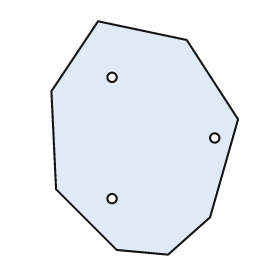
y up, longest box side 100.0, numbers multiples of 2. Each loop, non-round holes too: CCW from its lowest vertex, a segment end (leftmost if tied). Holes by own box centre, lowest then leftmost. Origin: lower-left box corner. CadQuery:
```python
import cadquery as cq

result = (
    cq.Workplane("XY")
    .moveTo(50.0, 0.0)
    .lineTo(68.0, 16.0)
    .lineTo(80.0, 58.0)
    .lineTo(58.0, 92.0)
    .lineTo(20.0, 100.0)
    .lineTo(0.0, 70.0)
    .lineTo(2.0, 28.0)
    .lineTo(28.0, 2.0)
    .close()
    .moveTo(26.0, 24.0)
    .circle(2.0)
    .moveTo(70.0, 50.0)
    .circle(2.0)
    .moveTo(26.0, 76.0)
    .circle(2.0)
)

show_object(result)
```